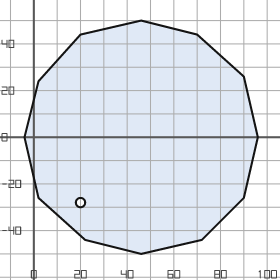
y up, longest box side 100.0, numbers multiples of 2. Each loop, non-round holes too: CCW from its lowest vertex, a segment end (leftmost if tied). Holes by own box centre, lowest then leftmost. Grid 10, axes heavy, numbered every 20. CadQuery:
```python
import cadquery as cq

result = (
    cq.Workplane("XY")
    .moveTo(46.0, -50.0)
    .lineTo(72.0, -44.0)
    .lineTo(90.0, -26.0)
    .lineTo(96.0, 0.0)
    .lineTo(90.0, 26.0)
    .lineTo(70.0, 44.0)
    .lineTo(46.0, 50.0)
    .lineTo(20.0, 44.0)
    .lineTo(2.0, 24.0)
    .lineTo(-4.0, 0.0)
    .lineTo(2.0, -26.0)
    .lineTo(22.0, -44.0)
    .close()
    .moveTo(20.0, -28.0)
    .circle(2.0)
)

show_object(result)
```